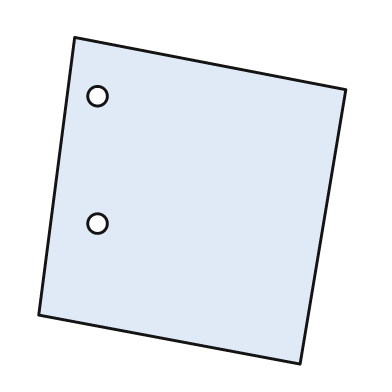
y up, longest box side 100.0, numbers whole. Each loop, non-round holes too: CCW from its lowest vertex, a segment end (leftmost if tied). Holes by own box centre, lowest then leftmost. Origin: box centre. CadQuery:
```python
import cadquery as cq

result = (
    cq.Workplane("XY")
    .moveTo(33.0, -50.0)
    .lineTo(47.0, 34.0)
    .lineTo(-36.0, 50.0)
    .lineTo(-47.0, -35.0)
    .close()
    .moveTo(-29.0, -7.0)
    .circle(3.0)
    .moveTo(-29.0, 32.0)
    .circle(3.0)
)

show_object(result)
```